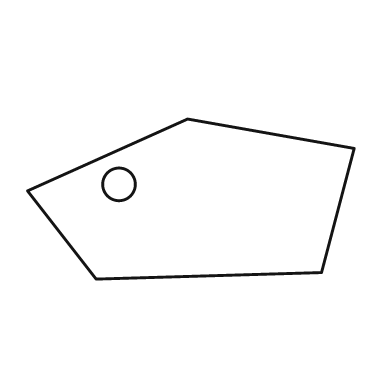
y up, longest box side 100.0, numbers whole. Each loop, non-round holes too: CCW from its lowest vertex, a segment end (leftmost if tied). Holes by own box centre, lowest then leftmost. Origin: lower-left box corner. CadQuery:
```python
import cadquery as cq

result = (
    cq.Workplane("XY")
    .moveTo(21.0, 0.0)
    .lineTo(90.0, 2.0)
    .lineTo(100.0, 40.0)
    .lineTo(49.0, 49.0)
    .lineTo(0.0, 27.0)
    .close()
    .moveTo(28.0, 29.0)
    .circle(5.0)
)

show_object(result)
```